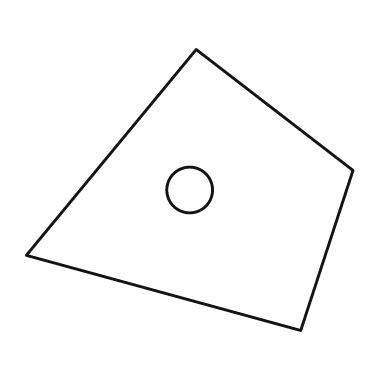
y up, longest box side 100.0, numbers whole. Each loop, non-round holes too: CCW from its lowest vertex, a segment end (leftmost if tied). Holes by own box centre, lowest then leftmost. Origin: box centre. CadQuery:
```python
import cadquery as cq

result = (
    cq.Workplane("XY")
    .moveTo(34.0, -43.0)
    .lineTo(50.0, 6.0)
    .lineTo(2.0, 43.0)
    .lineTo(-50.0, -20.0)
    .close()
    .moveTo(0.0, 0.0)
    .circle(7.0)
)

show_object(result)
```